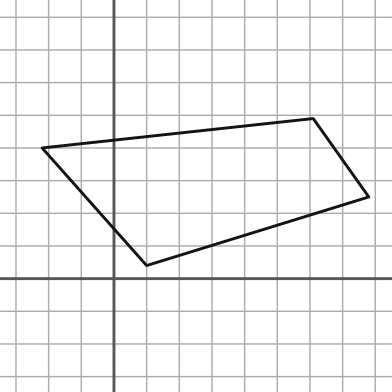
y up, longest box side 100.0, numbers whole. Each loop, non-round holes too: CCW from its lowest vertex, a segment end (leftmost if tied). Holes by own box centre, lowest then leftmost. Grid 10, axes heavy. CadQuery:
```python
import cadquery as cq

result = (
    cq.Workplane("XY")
    .moveTo(10.0, 4.0)
    .lineTo(78.0, 25.0)
    .lineTo(61.0, 49.0)
    .lineTo(-22.0, 40.0)
    .close()
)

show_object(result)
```